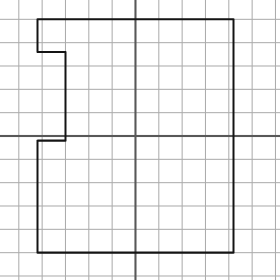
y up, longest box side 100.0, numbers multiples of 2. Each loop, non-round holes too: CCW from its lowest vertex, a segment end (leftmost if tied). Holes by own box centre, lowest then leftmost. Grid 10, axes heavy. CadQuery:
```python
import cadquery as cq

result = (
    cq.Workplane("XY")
    .moveTo(-42.0, -50.0)
    .lineTo(42.0, -50.0)
    .lineTo(42.0, 50.0)
    .lineTo(-42.0, 50.0)
    .lineTo(-42.0, 36.0)
    .lineTo(-30.0, 36.0)
    .lineTo(-30.0, -2.0)
    .lineTo(-42.0, -2.0)
    .close()
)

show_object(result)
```